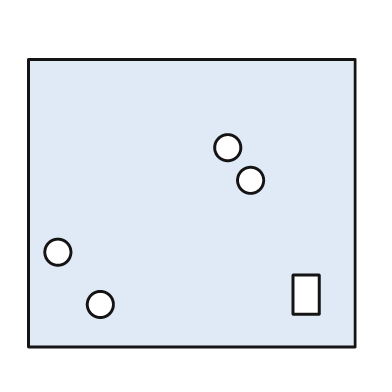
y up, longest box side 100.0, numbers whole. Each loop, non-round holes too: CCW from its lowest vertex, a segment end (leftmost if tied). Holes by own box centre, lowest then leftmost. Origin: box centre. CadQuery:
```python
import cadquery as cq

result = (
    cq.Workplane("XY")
    .moveTo(-50.0, -44.0)
    .lineTo(50.0, -44.0)
    .lineTo(50.0, 44.0)
    .lineTo(-50.0, 44.0)
    .close()
    .moveTo(-28.0, -31.0)
    .circle(4.0)
    .moveTo(31.0, -34.0)
    .lineTo(39.0, -34.0)
    .lineTo(39.0, -22.0)
    .lineTo(31.0, -22.0)
    .close()
    .moveTo(-41.0, -15.0)
    .circle(4.0)
    .moveTo(18.0, 7.0)
    .circle(4.0)
    .moveTo(11.0, 17.0)
    .circle(4.0)
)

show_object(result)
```